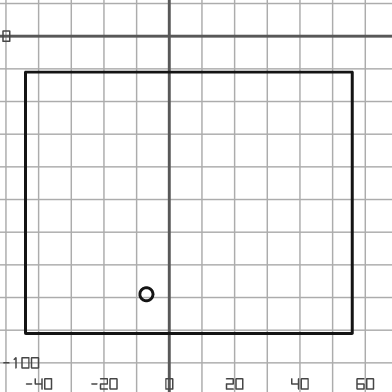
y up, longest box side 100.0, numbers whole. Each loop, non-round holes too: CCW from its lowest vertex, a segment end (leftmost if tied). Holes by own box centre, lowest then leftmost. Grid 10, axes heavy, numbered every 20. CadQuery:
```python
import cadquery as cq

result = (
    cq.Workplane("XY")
    .moveTo(-44.0, -91.0)
    .lineTo(56.0, -91.0)
    .lineTo(56.0, -11.0)
    .lineTo(-44.0, -11.0)
    .close()
    .moveTo(-7.0, -79.0)
    .circle(2.0)
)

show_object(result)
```